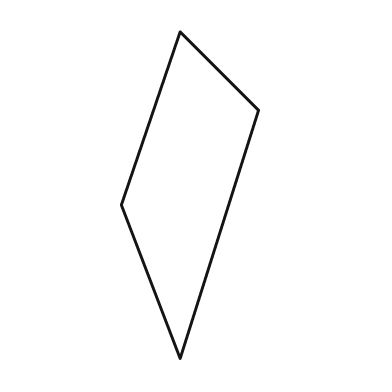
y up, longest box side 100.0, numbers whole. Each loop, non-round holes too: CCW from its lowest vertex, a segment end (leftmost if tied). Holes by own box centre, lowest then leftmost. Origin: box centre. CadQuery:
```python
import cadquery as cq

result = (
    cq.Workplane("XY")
    .moveTo(-3.0, -50.0)
    .lineTo(21.0, 26.0)
    .lineTo(-3.0, 50.0)
    .lineTo(-21.0, -3.0)
    .close()
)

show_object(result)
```